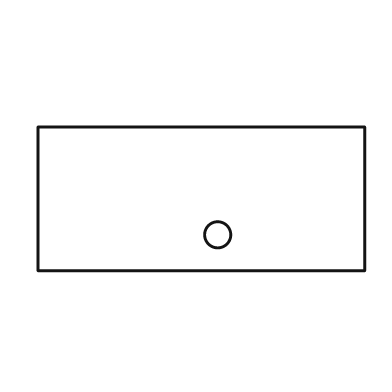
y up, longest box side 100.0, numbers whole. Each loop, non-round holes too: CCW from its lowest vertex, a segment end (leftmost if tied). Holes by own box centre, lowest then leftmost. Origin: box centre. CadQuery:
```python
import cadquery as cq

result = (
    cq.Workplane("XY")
    .moveTo(-50.0, -22.0)
    .lineTo(50.0, -22.0)
    .lineTo(50.0, 22.0)
    .lineTo(-50.0, 22.0)
    .close()
    .moveTo(5.0, -11.0)
    .circle(4.0)
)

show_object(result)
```